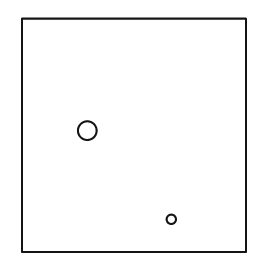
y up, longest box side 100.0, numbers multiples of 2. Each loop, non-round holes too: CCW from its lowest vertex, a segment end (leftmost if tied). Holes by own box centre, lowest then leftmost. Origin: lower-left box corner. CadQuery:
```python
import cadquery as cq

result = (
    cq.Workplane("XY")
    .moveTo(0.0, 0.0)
    .lineTo(96.0, 0.0)
    .lineTo(96.0, 100.0)
    .lineTo(0.0, 100.0)
    .close()
    .moveTo(64.0, 14.0)
    .circle(2.0)
    .moveTo(28.0, 52.0)
    .circle(4.0)
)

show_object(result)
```